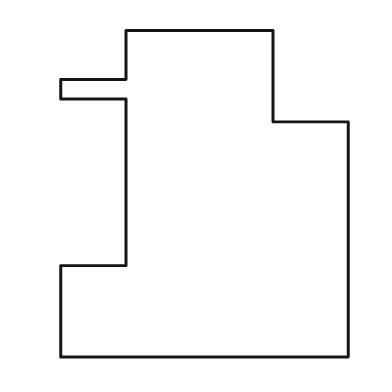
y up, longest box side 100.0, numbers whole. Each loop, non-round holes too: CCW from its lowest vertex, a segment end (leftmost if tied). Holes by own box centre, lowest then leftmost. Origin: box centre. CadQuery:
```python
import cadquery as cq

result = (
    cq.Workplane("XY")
    .moveTo(-44.0, -50.0)
    .lineTo(44.0, -50.0)
    .lineTo(44.0, 22.0)
    .lineTo(21.0, 22.0)
    .lineTo(21.0, 50.0)
    .lineTo(-24.0, 50.0)
    .lineTo(-24.0, 35.0)
    .lineTo(-44.0, 35.0)
    .lineTo(-44.0, 29.0)
    .lineTo(-24.0, 29.0)
    .lineTo(-24.0, -22.0)
    .lineTo(-44.0, -22.0)
    .close()
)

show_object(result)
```